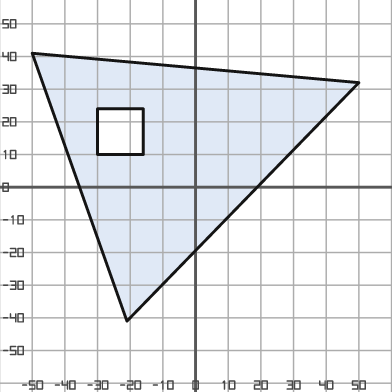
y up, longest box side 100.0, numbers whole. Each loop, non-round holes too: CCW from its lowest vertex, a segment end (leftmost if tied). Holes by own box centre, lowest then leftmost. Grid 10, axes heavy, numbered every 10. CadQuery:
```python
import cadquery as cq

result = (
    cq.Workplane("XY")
    .moveTo(-21.0, -41.0)
    .lineTo(50.0, 32.0)
    .lineTo(-50.0, 41.0)
    .close()
    .moveTo(-30.0, 10.0)
    .lineTo(-16.0, 10.0)
    .lineTo(-16.0, 24.0)
    .lineTo(-30.0, 24.0)
    .close()
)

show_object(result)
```